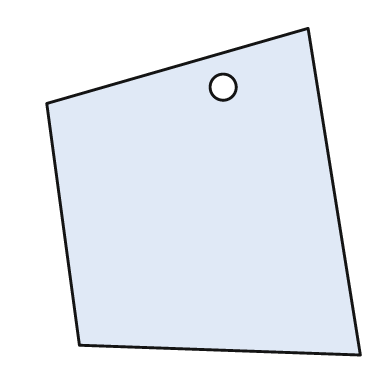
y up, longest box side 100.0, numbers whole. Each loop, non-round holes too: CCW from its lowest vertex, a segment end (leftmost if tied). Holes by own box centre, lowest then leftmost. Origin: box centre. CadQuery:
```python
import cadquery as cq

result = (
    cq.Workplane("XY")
    .moveTo(48.0, -50.0)
    .lineTo(32.0, 50.0)
    .lineTo(-48.0, 27.0)
    .lineTo(-38.0, -47.0)
    .close()
    .moveTo(6.0, 32.0)
    .circle(4.0)
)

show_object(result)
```